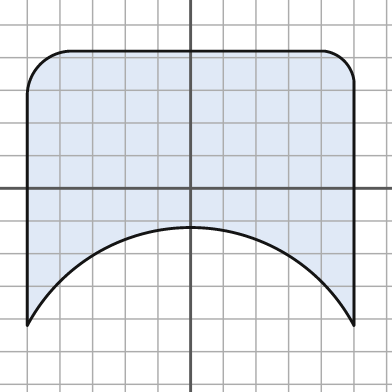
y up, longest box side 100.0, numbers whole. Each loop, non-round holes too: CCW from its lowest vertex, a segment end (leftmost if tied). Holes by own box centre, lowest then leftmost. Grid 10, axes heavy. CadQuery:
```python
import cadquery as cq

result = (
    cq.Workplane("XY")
    .moveTo(-50.0, -42.0)
    .threePointArc((0.0, -12.0), (50.0, -42.0))
    .lineTo(50.0, 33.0)
    .threePointArc((47.0, 39.0), (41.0, 42.0))
    .lineTo(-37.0, 42.0)
    .threePointArc((-46.0, 38.0), (-50.0, 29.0))
    .close()
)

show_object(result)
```